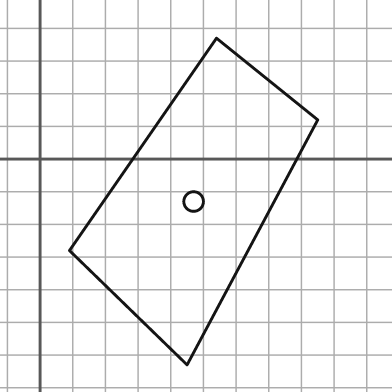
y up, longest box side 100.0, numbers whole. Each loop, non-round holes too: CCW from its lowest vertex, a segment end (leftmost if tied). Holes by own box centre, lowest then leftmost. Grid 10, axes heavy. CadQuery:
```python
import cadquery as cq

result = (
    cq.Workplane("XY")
    .moveTo(45.0, -63.0)
    .lineTo(85.0, 12.0)
    .lineTo(54.0, 37.0)
    .lineTo(9.0, -28.0)
    .close()
    .moveTo(47.0, -13.0)
    .circle(3.0)
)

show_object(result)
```